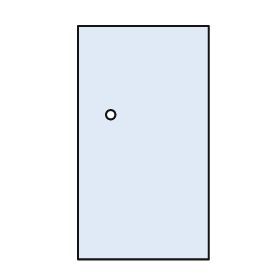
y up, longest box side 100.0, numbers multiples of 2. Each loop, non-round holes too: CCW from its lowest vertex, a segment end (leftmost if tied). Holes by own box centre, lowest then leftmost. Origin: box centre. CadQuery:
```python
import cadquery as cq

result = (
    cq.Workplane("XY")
    .moveTo(-28.0, -50.0)
    .lineTo(28.0, -50.0)
    .lineTo(28.0, 50.0)
    .lineTo(-28.0, 50.0)
    .close()
    .moveTo(-14.0, 12.0)
    .circle(2.0)
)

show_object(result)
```